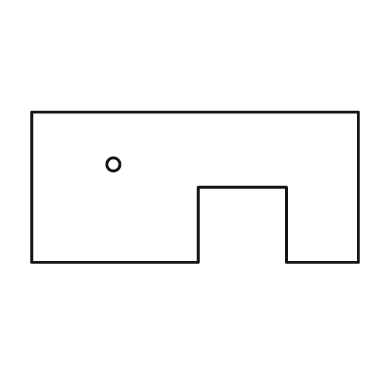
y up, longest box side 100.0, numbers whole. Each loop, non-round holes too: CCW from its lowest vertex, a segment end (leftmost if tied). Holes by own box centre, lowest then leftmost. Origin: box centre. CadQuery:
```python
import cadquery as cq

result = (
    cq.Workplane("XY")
    .moveTo(-50.0, -23.0)
    .lineTo(1.0, -23.0)
    .lineTo(1.0, 0.0)
    .lineTo(28.0, 0.0)
    .lineTo(28.0, -23.0)
    .lineTo(50.0, -23.0)
    .lineTo(50.0, 23.0)
    .lineTo(-50.0, 23.0)
    .close()
    .moveTo(-25.0, 7.0)
    .circle(2.0)
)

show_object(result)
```